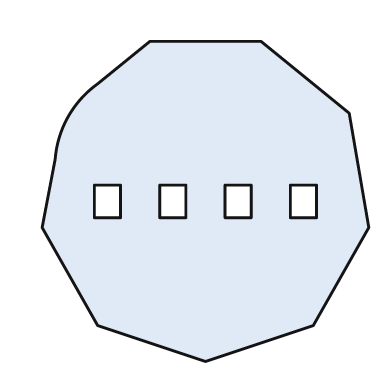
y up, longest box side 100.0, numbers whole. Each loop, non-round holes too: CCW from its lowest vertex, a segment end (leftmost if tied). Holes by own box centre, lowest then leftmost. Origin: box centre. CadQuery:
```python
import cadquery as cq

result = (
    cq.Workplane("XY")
    .moveTo(0.0, -49.0)
    .lineTo(33.0, -38.0)
    .lineTo(50.0, -8.0)
    .lineTo(44.0, 27.0)
    .lineTo(17.0, 49.0)
    .lineTo(-17.0, 49.0)
    .lineTo(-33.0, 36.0)
    .threePointArc((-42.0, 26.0), (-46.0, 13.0))
    .lineTo(-50.0, -8.0)
    .lineTo(-33.0, -38.0)
    .close()
    .moveTo(-34.0, -5.0)
    .lineTo(-26.0, -5.0)
    .lineTo(-26.0, 5.0)
    .lineTo(-34.0, 5.0)
    .close()
    .moveTo(-14.0, -5.0)
    .lineTo(-6.0, -5.0)
    .lineTo(-6.0, 5.0)
    .lineTo(-14.0, 5.0)
    .close()
    .moveTo(6.0, -5.0)
    .lineTo(14.0, -5.0)
    .lineTo(14.0, 5.0)
    .lineTo(6.0, 5.0)
    .close()
    .moveTo(26.0, -5.0)
    .lineTo(34.0, -5.0)
    .lineTo(34.0, 5.0)
    .lineTo(26.0, 5.0)
    .close()
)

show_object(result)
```